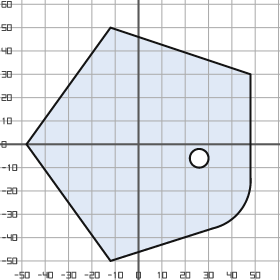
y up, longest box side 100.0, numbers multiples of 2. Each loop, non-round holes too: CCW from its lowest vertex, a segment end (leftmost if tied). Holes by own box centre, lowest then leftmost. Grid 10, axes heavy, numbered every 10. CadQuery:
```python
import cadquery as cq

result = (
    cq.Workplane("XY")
    .moveTo(-12.0, -50.0)
    .lineTo(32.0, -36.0)
    .threePointArc((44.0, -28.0), (48.0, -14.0))
    .lineTo(48.0, 30.0)
    .lineTo(-12.0, 50.0)
    .lineTo(-48.0, 0.0)
    .close()
    .moveTo(26.0, -6.0)
    .circle(4.0)
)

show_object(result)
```